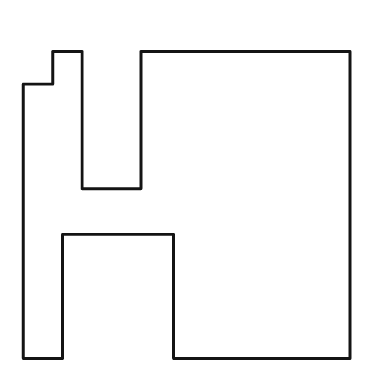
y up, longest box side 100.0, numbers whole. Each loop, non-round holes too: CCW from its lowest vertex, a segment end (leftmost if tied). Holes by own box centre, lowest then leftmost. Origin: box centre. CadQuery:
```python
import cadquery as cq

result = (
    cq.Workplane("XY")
    .moveTo(-50.0, -47.0)
    .lineTo(-38.0, -47.0)
    .lineTo(-38.0, -9.0)
    .lineTo(-4.0, -9.0)
    .lineTo(-4.0, -47.0)
    .lineTo(50.0, -47.0)
    .lineTo(50.0, 47.0)
    .lineTo(-14.0, 47.0)
    .lineTo(-14.0, 5.0)
    .lineTo(-32.0, 5.0)
    .lineTo(-32.0, 47.0)
    .lineTo(-41.0, 47.0)
    .lineTo(-41.0, 37.0)
    .lineTo(-50.0, 37.0)
    .close()
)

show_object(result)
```